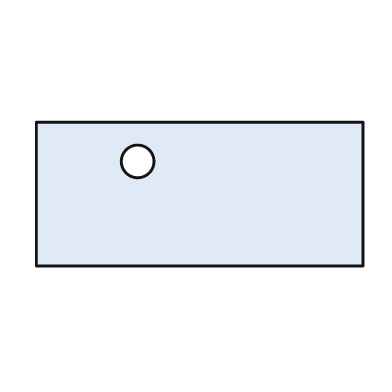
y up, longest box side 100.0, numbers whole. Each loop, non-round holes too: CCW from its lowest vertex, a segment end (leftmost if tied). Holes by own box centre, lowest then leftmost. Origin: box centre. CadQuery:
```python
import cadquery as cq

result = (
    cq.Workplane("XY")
    .moveTo(-50.0, -22.0)
    .lineTo(50.0, -22.0)
    .lineTo(50.0, 22.0)
    .lineTo(-50.0, 22.0)
    .close()
    .moveTo(-19.0, 10.0)
    .circle(5.0)
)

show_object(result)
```